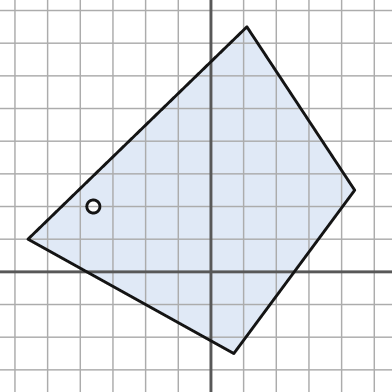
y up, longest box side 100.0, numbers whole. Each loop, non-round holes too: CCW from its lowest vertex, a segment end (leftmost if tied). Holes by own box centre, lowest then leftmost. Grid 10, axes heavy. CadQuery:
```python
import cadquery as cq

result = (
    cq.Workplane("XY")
    .moveTo(7.0, -25.0)
    .lineTo(44.0, 25.0)
    .lineTo(11.0, 75.0)
    .lineTo(-56.0, 10.0)
    .close()
    .moveTo(-36.0, 20.0)
    .circle(2.0)
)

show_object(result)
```